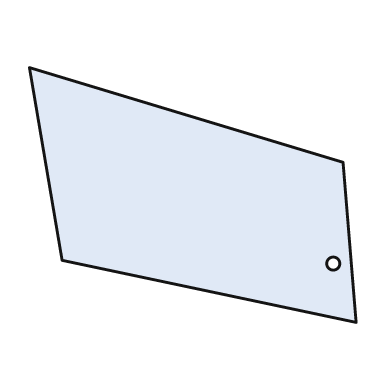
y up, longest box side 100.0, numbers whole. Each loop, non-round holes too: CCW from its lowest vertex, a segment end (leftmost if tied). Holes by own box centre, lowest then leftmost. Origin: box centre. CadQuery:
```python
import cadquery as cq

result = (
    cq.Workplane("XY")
    .moveTo(50.0, -39.0)
    .lineTo(46.0, 10.0)
    .lineTo(-50.0, 39.0)
    .lineTo(-40.0, -20.0)
    .close()
    .moveTo(43.0, -21.0)
    .circle(2.0)
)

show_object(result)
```